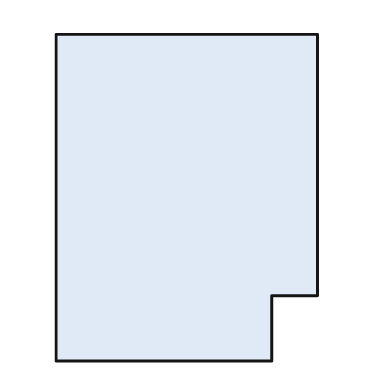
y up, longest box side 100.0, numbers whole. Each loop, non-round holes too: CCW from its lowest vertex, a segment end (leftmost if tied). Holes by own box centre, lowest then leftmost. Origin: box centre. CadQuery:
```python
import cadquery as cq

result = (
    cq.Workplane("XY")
    .moveTo(-40.0, -50.0)
    .lineTo(26.0, -50.0)
    .lineTo(26.0, -30.0)
    .lineTo(40.0, -30.0)
    .lineTo(40.0, 50.0)
    .lineTo(-40.0, 50.0)
    .close()
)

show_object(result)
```